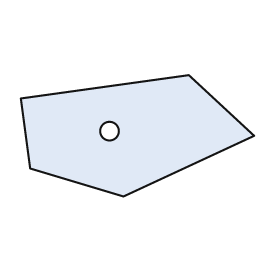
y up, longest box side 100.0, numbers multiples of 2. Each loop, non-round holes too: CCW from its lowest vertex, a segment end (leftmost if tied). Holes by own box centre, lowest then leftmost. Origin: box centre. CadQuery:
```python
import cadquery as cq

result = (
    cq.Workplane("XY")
    .moveTo(-6.0, -26.0)
    .lineTo(50.0, 0.0)
    .lineTo(22.0, 26.0)
    .lineTo(-50.0, 16.0)
    .lineTo(-46.0, -14.0)
    .close()
    .moveTo(-12.0, 2.0)
    .circle(4.0)
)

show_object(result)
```